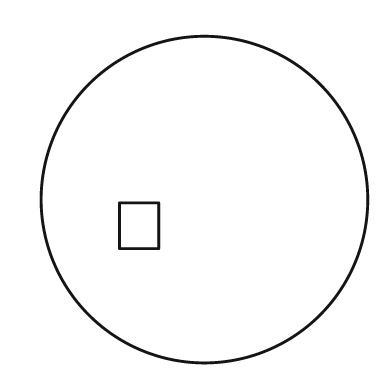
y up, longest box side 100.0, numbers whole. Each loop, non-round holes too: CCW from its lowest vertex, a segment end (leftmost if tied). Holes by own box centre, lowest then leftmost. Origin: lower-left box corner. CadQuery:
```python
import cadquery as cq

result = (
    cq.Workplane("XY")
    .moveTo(50.0, 50.0)
    .circle(50.0)
    .moveTo(24.0, 35.0)
    .lineTo(36.0, 35.0)
    .lineTo(36.0, 49.0)
    .lineTo(24.0, 49.0)
    .close()
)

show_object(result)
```